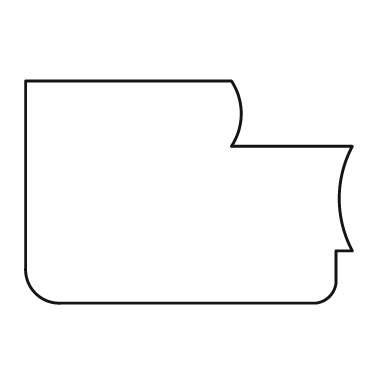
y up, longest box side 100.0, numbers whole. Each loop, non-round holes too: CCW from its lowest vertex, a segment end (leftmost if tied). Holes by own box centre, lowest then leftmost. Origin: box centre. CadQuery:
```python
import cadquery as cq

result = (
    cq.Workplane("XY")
    .moveTo(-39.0, -34.0)
    .lineTo(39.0, -34.0)
    .threePointArc((43.0, -32.0), (45.0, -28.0))
    .lineTo(45.0, -18.0)
    .lineTo(50.0, -18.0)
    .threePointArc((46.0, -2.0), (50.0, 14.0))
    .lineTo(13.0, 14.0)
    .threePointArc((16.0, 24.0), (13.0, 34.0))
    .lineTo(-50.0, 34.0)
    .lineTo(-50.0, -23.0)
    .threePointArc((-47.0, -31.0), (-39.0, -34.0))
    .close()
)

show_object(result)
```